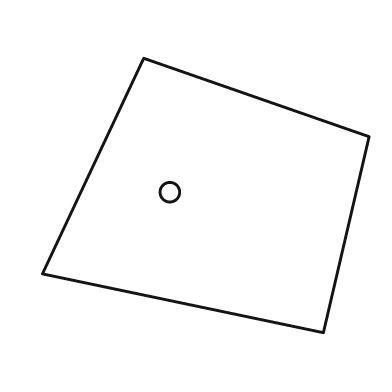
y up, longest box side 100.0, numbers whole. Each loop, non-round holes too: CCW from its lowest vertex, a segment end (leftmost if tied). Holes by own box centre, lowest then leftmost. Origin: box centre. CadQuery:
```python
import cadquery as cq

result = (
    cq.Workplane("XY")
    .moveTo(36.0, -42.0)
    .lineTo(50.0, 18.0)
    .lineTo(-19.0, 42.0)
    .lineTo(-50.0, -24.0)
    .close()
    .moveTo(-11.0, 1.0)
    .circle(3.0)
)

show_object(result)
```